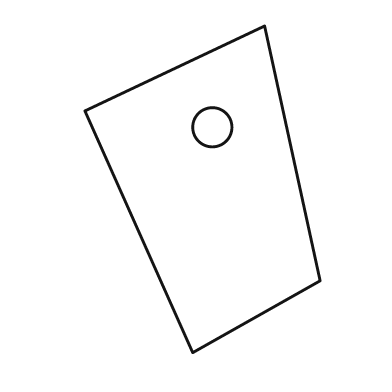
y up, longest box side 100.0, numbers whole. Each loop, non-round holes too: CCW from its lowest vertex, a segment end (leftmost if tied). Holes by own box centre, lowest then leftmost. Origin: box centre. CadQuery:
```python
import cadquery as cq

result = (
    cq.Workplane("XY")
    .moveTo(-3.0, -50.0)
    .lineTo(36.0, -28.0)
    .lineTo(19.0, 50.0)
    .lineTo(-36.0, 24.0)
    .close()
    .moveTo(3.0, 19.0)
    .circle(6.0)
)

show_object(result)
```